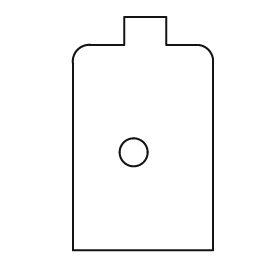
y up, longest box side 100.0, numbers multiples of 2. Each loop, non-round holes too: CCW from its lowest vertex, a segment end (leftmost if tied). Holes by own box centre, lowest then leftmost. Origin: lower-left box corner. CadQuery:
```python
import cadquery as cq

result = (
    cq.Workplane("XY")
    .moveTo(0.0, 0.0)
    .lineTo(60.0, 0.0)
    .lineTo(60.0, 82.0)
    .threePointArc((58.0, 86.0), (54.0, 88.0))
    .lineTo(40.0, 88.0)
    .lineTo(40.0, 100.0)
    .lineTo(22.0, 100.0)
    .lineTo(22.0, 88.0)
    .lineTo(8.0, 88.0)
    .threePointArc((2.0, 86.0), (0.0, 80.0))
    .close()
    .moveTo(26.0, 42.0)
    .circle(6.0)
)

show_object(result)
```